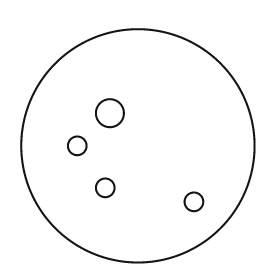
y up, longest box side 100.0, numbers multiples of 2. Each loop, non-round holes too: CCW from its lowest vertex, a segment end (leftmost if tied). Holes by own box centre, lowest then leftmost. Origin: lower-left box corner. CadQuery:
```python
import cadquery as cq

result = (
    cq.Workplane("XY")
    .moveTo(50.0, 50.0)
    .circle(50.0)
    .moveTo(74.0, 26.0)
    .circle(4.0)
    .moveTo(36.0, 32.0)
    .circle(4.0)
    .moveTo(24.0, 50.0)
    .circle(4.0)
    .moveTo(38.0, 64.0)
    .circle(6.0)
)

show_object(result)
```